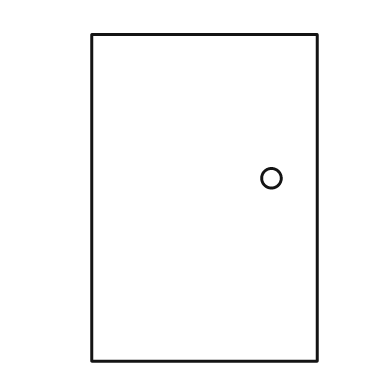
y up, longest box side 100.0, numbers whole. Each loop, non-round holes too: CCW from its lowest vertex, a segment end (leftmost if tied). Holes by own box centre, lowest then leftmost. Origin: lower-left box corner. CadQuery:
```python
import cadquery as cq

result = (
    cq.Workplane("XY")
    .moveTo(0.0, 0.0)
    .lineTo(69.0, 0.0)
    .lineTo(69.0, 100.0)
    .lineTo(0.0, 100.0)
    .close()
    .moveTo(55.0, 56.0)
    .circle(3.0)
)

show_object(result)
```